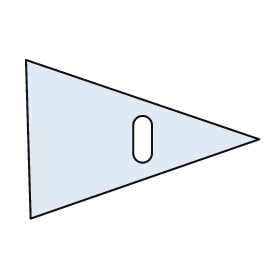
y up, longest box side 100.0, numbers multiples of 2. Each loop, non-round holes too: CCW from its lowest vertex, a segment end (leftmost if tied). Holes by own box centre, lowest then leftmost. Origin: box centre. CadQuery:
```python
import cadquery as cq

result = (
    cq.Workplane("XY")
    .moveTo(-48.0, -34.0)
    .lineTo(50.0, 0.0)
    .lineTo(-50.0, 34.0)
    .close()
    .moveTo(-4.0, -6.0)
    .threePointArc((0.0, -10.0), (4.0, -6.0))
    .lineTo(4.0, 6.0)
    .threePointArc((0.0, 10.0), (-4.0, 6.0))
    .close()
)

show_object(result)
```